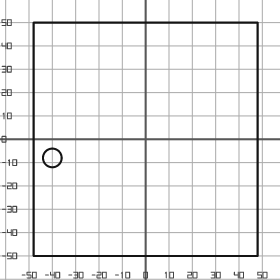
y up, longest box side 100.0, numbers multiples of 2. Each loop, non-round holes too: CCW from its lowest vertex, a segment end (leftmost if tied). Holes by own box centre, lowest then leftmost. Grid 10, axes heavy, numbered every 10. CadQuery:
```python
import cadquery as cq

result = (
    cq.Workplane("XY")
    .moveTo(-48.0, -50.0)
    .lineTo(48.0, -50.0)
    .lineTo(48.0, 50.0)
    .lineTo(-48.0, 50.0)
    .close()
    .moveTo(-40.0, -8.0)
    .circle(4.0)
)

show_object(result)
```